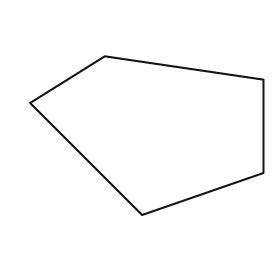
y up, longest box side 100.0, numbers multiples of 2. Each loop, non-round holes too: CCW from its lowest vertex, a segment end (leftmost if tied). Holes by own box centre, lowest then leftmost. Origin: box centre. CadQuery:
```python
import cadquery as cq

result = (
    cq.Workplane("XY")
    .moveTo(-2.0, -34.0)
    .lineTo(50.0, -16.0)
    .lineTo(50.0, 24.0)
    .lineTo(-18.0, 34.0)
    .lineTo(-50.0, 14.0)
    .close()
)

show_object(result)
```